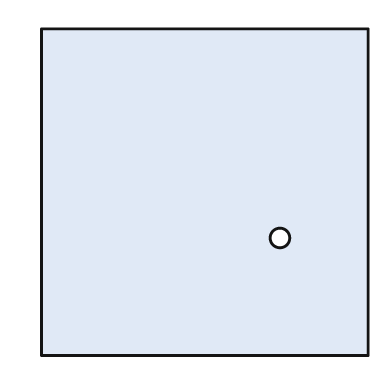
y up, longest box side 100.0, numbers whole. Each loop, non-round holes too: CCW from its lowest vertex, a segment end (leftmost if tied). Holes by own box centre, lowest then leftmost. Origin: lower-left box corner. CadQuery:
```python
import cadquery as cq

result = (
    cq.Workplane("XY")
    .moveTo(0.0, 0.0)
    .lineTo(100.0, 0.0)
    .lineTo(100.0, 100.0)
    .lineTo(0.0, 100.0)
    .close()
    .moveTo(73.0, 36.0)
    .circle(3.0)
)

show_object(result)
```